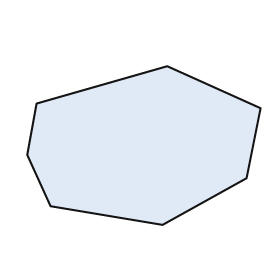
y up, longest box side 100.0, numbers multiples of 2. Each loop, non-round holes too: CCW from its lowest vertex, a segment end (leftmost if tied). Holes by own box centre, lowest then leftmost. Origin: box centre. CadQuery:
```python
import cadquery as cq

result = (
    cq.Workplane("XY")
    .moveTo(8.0, -34.0)
    .lineTo(44.0, -14.0)
    .lineTo(50.0, 16.0)
    .lineTo(10.0, 34.0)
    .lineTo(-46.0, 18.0)
    .lineTo(-50.0, -4.0)
    .lineTo(-40.0, -26.0)
    .close()
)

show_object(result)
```